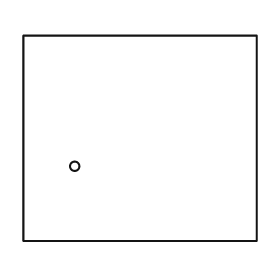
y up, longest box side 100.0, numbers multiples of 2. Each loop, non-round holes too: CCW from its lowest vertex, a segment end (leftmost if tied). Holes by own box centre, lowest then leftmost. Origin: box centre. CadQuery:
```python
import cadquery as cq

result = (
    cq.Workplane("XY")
    .moveTo(-50.0, -44.0)
    .lineTo(50.0, -44.0)
    .lineTo(50.0, 44.0)
    .lineTo(-50.0, 44.0)
    .close()
    .moveTo(-28.0, -12.0)
    .circle(2.0)
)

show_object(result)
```